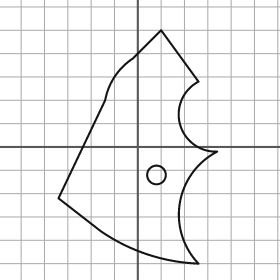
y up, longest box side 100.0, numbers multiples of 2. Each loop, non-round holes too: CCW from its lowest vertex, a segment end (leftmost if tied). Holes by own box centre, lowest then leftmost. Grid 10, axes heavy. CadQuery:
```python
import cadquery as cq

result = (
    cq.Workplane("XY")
    .moveTo(26.0, -50.0)
    .threePointArc((18.0, -24.0), (34.0, -2.0))
    .threePointArc((18.0, 10.0), (26.0, 28.0))
    .lineTo(10.0, 50.0)
    .lineTo(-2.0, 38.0)
    .threePointArc((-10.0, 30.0), (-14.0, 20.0))
    .lineTo(-34.0, -22.0)
    .lineTo(-16.0, -36.0)
    .threePointArc((4.0, -46.0), (26.0, -50.0))
    .close()
    .moveTo(8.0, -12.0)
    .circle(4.0)
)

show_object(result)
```